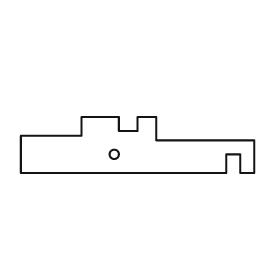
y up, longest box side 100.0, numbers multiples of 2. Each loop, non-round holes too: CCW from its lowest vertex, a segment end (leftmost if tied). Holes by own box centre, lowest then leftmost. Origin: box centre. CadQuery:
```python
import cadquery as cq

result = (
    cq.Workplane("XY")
    .moveTo(-50.0, -12.0)
    .lineTo(38.0, -12.0)
    .lineTo(38.0, -4.0)
    .lineTo(44.0, -4.0)
    .lineTo(44.0, -12.0)
    .lineTo(50.0, -12.0)
    .lineTo(50.0, 2.0)
    .lineTo(8.0, 2.0)
    .lineTo(8.0, 12.0)
    .lineTo(0.0, 12.0)
    .lineTo(0.0, 6.0)
    .lineTo(-8.0, 6.0)
    .lineTo(-8.0, 12.0)
    .lineTo(-24.0, 12.0)
    .lineTo(-24.0, 4.0)
    .lineTo(-50.0, 4.0)
    .close()
    .moveTo(-10.0, -4.0)
    .circle(2.0)
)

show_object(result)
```